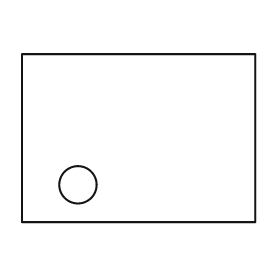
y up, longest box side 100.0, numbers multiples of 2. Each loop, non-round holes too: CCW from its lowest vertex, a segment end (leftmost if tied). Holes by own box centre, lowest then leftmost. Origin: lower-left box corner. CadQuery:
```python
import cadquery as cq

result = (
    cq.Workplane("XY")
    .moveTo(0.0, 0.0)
    .lineTo(100.0, 0.0)
    .lineTo(100.0, 72.0)
    .lineTo(0.0, 72.0)
    .close()
    .moveTo(24.0, 16.0)
    .circle(8.0)
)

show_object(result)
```